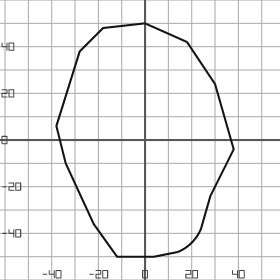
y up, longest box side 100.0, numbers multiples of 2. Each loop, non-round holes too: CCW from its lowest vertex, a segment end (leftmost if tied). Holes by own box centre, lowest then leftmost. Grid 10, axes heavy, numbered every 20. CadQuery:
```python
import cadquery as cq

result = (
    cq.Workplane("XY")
    .moveTo(-12.0, -50.0)
    .lineTo(4.0, -50.0)
    .lineTo(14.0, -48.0)
    .threePointArc((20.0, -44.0), (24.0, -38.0))
    .lineTo(28.0, -24.0)
    .lineTo(38.0, -4.0)
    .lineTo(30.0, 24.0)
    .lineTo(18.0, 42.0)
    .lineTo(0.0, 50.0)
    .lineTo(-18.0, 48.0)
    .lineTo(-28.0, 38.0)
    .lineTo(-38.0, 6.0)
    .lineTo(-34.0, -10.0)
    .lineTo(-22.0, -36.0)
    .close()
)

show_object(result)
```